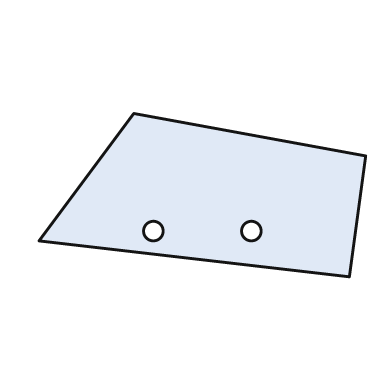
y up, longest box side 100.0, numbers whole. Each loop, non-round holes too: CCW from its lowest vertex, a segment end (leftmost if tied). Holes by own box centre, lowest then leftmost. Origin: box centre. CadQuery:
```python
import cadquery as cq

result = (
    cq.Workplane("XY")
    .moveTo(45.0, -25.0)
    .lineTo(50.0, 12.0)
    .lineTo(-21.0, 25.0)
    .lineTo(-50.0, -14.0)
    .close()
    .moveTo(-15.0, -11.0)
    .circle(3.0)
    .moveTo(15.0, -11.0)
    .circle(3.0)
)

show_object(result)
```